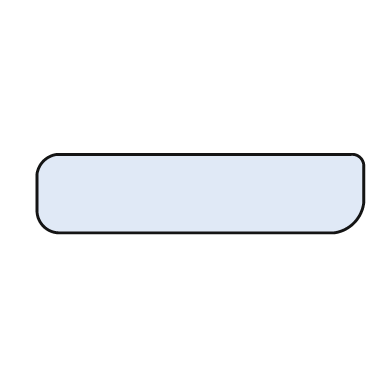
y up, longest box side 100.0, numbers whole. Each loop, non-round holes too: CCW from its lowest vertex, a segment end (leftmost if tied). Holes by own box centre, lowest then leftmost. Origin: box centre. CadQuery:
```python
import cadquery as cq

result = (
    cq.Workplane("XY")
    .moveTo(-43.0, -12.0)
    .lineTo(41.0, -12.0)
    .threePointArc((47.0, -9.0), (50.0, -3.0))
    .lineTo(50.0, 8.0)
    .threePointArc((49.0, 11.0), (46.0, 12.0))
    .lineTo(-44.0, 12.0)
    .threePointArc((-48.0, 10.0), (-50.0, 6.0))
    .lineTo(-50.0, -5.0)
    .threePointArc((-48.0, -10.0), (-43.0, -12.0))
    .close()
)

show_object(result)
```